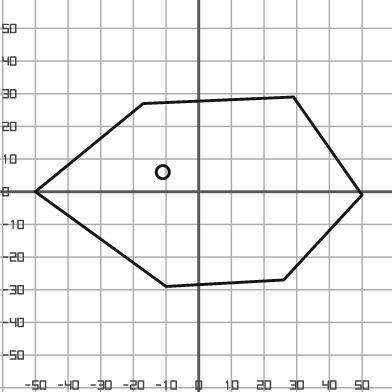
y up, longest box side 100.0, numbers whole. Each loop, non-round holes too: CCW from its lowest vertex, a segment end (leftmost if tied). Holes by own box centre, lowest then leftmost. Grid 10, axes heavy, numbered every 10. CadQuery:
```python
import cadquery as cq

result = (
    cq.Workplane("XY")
    .moveTo(-10.0, -29.0)
    .lineTo(26.0, -27.0)
    .lineTo(50.0, -1.0)
    .lineTo(29.0, 29.0)
    .lineTo(-17.0, 27.0)
    .lineTo(-50.0, 0.0)
    .close()
    .moveTo(-11.0, 6.0)
    .circle(2.0)
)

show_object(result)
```